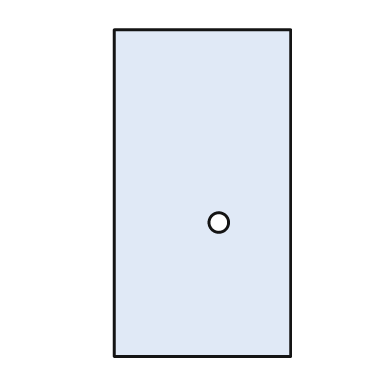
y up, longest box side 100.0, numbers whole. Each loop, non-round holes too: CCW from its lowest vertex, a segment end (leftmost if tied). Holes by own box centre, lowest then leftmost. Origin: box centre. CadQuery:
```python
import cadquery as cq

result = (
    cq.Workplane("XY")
    .moveTo(-27.0, -50.0)
    .lineTo(27.0, -50.0)
    .lineTo(27.0, 50.0)
    .lineTo(-27.0, 50.0)
    .close()
    .moveTo(5.0, -9.0)
    .circle(3.0)
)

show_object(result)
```